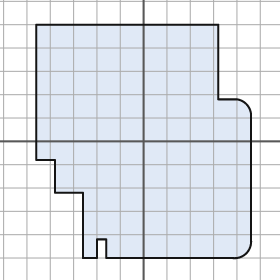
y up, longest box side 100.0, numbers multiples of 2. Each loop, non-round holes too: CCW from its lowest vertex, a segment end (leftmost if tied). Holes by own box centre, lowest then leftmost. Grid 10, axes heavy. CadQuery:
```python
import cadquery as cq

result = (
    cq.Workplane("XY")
    .moveTo(-26.0, -50.0)
    .lineTo(-20.0, -50.0)
    .lineTo(-20.0, -42.0)
    .lineTo(-16.0, -42.0)
    .lineTo(-16.0, -50.0)
    .lineTo(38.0, -50.0)
    .threePointArc((44.0, -48.0), (46.0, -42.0))
    .lineTo(46.0, 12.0)
    .threePointArc((44.0, 16.0), (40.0, 18.0))
    .lineTo(32.0, 18.0)
    .lineTo(32.0, 50.0)
    .lineTo(-46.0, 50.0)
    .lineTo(-46.0, -8.0)
    .lineTo(-38.0, -8.0)
    .lineTo(-38.0, -22.0)
    .lineTo(-26.0, -22.0)
    .close()
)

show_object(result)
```